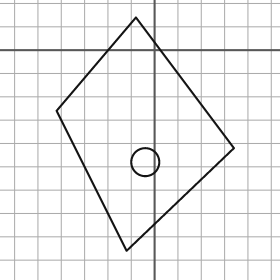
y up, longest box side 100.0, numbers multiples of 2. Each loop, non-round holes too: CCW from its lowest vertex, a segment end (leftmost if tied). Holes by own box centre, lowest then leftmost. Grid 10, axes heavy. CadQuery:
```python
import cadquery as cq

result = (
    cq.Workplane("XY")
    .moveTo(-12.0, -86.0)
    .lineTo(34.0, -42.0)
    .lineTo(-8.0, 14.0)
    .lineTo(-42.0, -26.0)
    .close()
    .moveTo(-4.0, -48.0)
    .circle(6.0)
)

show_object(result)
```